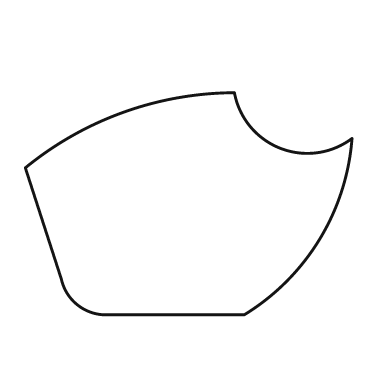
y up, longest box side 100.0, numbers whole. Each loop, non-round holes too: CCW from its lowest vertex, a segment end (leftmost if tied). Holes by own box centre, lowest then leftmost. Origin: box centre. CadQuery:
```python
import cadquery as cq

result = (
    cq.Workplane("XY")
    .moveTo(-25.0, -34.0)
    .lineTo(17.0, -34.0)
    .threePointArc((40.0, -11.0), (50.0, 20.0))
    .threePointArc((28.0, 17.0), (14.0, 34.0))
    .threePointArc((-20.0, 28.0), (-50.0, 11.0))
    .lineTo(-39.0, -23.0)
    .threePointArc((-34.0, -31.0), (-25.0, -34.0))
    .close()
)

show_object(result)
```